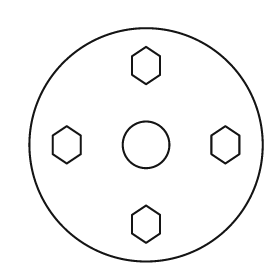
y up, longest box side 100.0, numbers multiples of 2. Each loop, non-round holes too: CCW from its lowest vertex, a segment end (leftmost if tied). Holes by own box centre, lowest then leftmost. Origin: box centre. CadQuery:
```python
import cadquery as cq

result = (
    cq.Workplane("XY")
    .moveTo(0.0, 0.0)
    .circle(50.0)
    .moveTo(0.0, -42.0)
    .lineTo(6.0, -38.0)
    .lineTo(6.0, -30.0)
    .lineTo(0.0, -26.0)
    .lineTo(-6.0, -30.0)
    .lineTo(-6.0, -38.0)
    .close()
    .moveTo(-34.0, -8.0)
    .lineTo(-28.0, -4.0)
    .lineTo(-28.0, 4.0)
    .lineTo(-34.0, 8.0)
    .lineTo(-40.0, 4.0)
    .lineTo(-40.0, -4.0)
    .close()
    .moveTo(0.0, 0.0)
    .circle(10.0)
    .moveTo(34.0, -8.0)
    .lineTo(40.0, -4.0)
    .lineTo(40.0, 4.0)
    .lineTo(34.0, 8.0)
    .lineTo(28.0, 4.0)
    .lineTo(28.0, -4.0)
    .close()
    .moveTo(0.0, 26.0)
    .lineTo(6.0, 30.0)
    .lineTo(6.0, 38.0)
    .lineTo(0.0, 42.0)
    .lineTo(-6.0, 38.0)
    .lineTo(-6.0, 30.0)
    .close()
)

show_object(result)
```